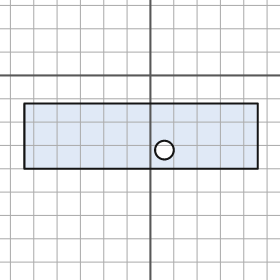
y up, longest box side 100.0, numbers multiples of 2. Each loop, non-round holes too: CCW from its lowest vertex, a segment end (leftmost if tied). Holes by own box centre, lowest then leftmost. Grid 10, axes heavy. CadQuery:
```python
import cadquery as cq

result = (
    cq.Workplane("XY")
    .moveTo(-54.0, -40.0)
    .lineTo(46.0, -40.0)
    .lineTo(46.0, -12.0)
    .lineTo(-54.0, -12.0)
    .close()
    .moveTo(6.0, -32.0)
    .circle(4.0)
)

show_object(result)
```